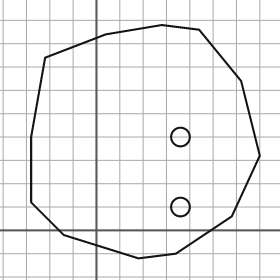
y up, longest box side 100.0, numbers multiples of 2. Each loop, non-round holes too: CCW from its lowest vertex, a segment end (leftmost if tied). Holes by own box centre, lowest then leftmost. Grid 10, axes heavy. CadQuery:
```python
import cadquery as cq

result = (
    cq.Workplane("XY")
    .moveTo(18.0, -12.0)
    .lineTo(34.0, -10.0)
    .lineTo(58.0, 6.0)
    .lineTo(70.0, 32.0)
    .lineTo(62.0, 64.0)
    .lineTo(44.0, 86.0)
    .lineTo(28.0, 88.0)
    .lineTo(4.0, 84.0)
    .lineTo(-22.0, 74.0)
    .lineTo(-28.0, 40.0)
    .lineTo(-28.0, 12.0)
    .lineTo(-14.0, -2.0)
    .close()
    .moveTo(36.0, 10.0)
    .circle(4.0)
    .moveTo(36.0, 40.0)
    .circle(4.0)
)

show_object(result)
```